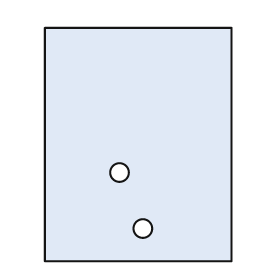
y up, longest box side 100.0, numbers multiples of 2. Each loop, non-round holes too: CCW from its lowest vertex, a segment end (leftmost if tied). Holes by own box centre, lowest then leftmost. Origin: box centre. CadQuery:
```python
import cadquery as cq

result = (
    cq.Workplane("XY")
    .moveTo(-40.0, -50.0)
    .lineTo(40.0, -50.0)
    .lineTo(40.0, 50.0)
    .lineTo(-40.0, 50.0)
    .close()
    .moveTo(2.0, -36.0)
    .circle(4.0)
    .moveTo(-8.0, -12.0)
    .circle(4.0)
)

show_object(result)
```